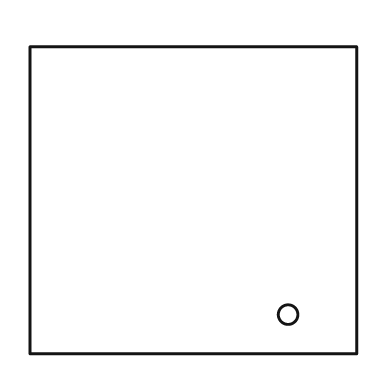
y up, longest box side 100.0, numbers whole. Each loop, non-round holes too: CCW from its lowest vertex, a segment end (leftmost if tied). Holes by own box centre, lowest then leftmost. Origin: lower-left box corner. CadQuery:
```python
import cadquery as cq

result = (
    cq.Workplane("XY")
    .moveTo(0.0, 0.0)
    .lineTo(100.0, 0.0)
    .lineTo(100.0, 94.0)
    .lineTo(0.0, 94.0)
    .close()
    .moveTo(79.0, 12.0)
    .circle(3.0)
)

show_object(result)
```